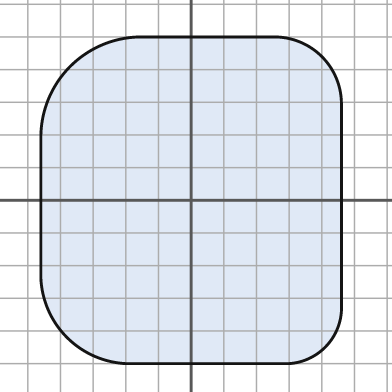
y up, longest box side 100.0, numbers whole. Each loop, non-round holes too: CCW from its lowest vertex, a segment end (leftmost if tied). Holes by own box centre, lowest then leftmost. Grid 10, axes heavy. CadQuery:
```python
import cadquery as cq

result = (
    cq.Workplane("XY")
    .moveTo(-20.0, -50.0)
    .lineTo(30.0, -50.0)
    .threePointArc((41.0, -45.0), (46.0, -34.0))
    .lineTo(46.0, 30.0)
    .threePointArc((40.0, 44.0), (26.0, 50.0))
    .lineTo(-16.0, 50.0)
    .threePointArc((-37.0, 41.0), (-46.0, 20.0))
    .lineTo(-46.0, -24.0)
    .threePointArc((-38.0, -42.0), (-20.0, -50.0))
    .close()
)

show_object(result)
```